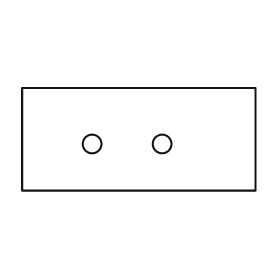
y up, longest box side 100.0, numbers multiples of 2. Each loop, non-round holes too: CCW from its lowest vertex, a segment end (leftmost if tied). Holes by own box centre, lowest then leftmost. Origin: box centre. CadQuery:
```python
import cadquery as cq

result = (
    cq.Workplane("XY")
    .moveTo(-50.0, -22.0)
    .lineTo(50.0, -22.0)
    .lineTo(50.0, 22.0)
    .lineTo(-50.0, 22.0)
    .close()
    .moveTo(-20.0, -2.0)
    .circle(4.0)
    .moveTo(10.0, -2.0)
    .circle(4.0)
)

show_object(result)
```